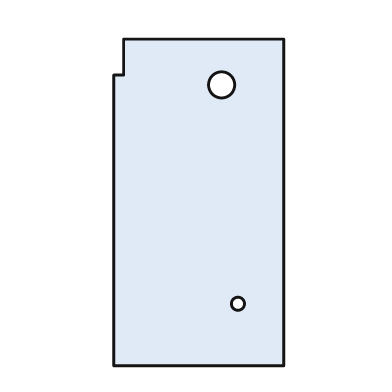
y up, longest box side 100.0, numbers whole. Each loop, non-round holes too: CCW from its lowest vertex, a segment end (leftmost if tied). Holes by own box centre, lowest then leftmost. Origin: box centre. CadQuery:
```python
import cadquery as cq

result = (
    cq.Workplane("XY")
    .moveTo(-26.0, -50.0)
    .lineTo(26.0, -50.0)
    .lineTo(26.0, 50.0)
    .lineTo(-23.0, 50.0)
    .lineTo(-23.0, 39.0)
    .lineTo(-26.0, 39.0)
    .close()
    .moveTo(12.0, -31.0)
    .circle(2.0)
    .moveTo(7.0, 36.0)
    .circle(4.0)
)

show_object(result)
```